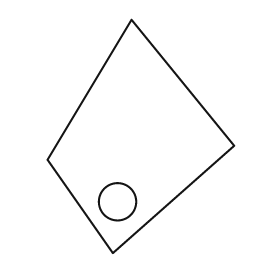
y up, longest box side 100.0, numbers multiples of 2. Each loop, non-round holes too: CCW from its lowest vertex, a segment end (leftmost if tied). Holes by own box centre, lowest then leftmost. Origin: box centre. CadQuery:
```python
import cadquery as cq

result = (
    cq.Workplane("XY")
    .moveTo(-12.0, -50.0)
    .lineTo(40.0, -4.0)
    .lineTo(-4.0, 50.0)
    .lineTo(-40.0, -10.0)
    .close()
    .moveTo(-10.0, -28.0)
    .circle(8.0)
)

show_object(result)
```